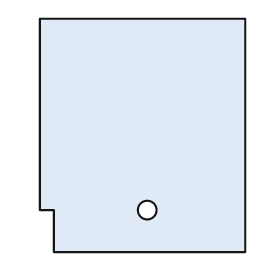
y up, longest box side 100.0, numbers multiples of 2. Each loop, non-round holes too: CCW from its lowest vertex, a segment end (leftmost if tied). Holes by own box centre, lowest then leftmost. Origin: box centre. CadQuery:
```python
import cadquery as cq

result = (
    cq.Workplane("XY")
    .moveTo(-38.0, -50.0)
    .lineTo(44.0, -50.0)
    .lineTo(44.0, 50.0)
    .lineTo(-44.0, 50.0)
    .lineTo(-44.0, -32.0)
    .lineTo(-38.0, -32.0)
    .close()
    .moveTo(2.0, -32.0)
    .circle(4.0)
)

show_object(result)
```